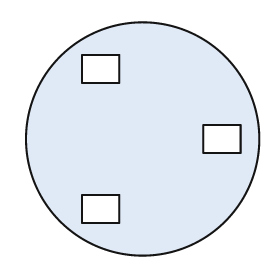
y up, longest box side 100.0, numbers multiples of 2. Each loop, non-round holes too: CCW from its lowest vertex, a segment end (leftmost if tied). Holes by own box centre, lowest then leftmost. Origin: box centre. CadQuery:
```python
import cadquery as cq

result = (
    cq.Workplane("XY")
    .moveTo(0.0, 0.0)
    .circle(50.0)
    .moveTo(-26.0, -36.0)
    .lineTo(-10.0, -36.0)
    .lineTo(-10.0, -24.0)
    .lineTo(-26.0, -24.0)
    .close()
    .moveTo(26.0, -6.0)
    .lineTo(42.0, -6.0)
    .lineTo(42.0, 6.0)
    .lineTo(26.0, 6.0)
    .close()
    .moveTo(-26.0, 24.0)
    .lineTo(-10.0, 24.0)
    .lineTo(-10.0, 36.0)
    .lineTo(-26.0, 36.0)
    .close()
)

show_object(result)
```